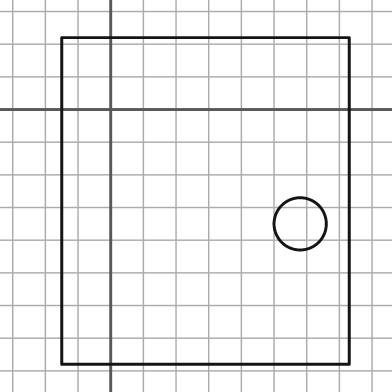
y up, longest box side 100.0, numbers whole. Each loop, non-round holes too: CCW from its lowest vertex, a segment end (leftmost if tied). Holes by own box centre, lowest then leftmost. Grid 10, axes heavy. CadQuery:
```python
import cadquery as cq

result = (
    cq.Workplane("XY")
    .moveTo(-15.0, -78.0)
    .lineTo(73.0, -78.0)
    .lineTo(73.0, 22.0)
    .lineTo(-15.0, 22.0)
    .close()
    .moveTo(58.0, -35.0)
    .circle(8.0)
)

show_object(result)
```